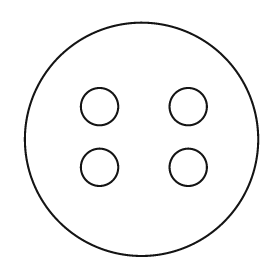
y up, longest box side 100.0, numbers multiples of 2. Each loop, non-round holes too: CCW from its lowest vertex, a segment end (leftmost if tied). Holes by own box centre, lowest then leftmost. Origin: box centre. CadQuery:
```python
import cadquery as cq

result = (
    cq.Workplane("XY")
    .moveTo(0.0, 0.0)
    .circle(50.0)
    .moveTo(-18.0, -12.0)
    .circle(8.0)
    .moveTo(20.0, -12.0)
    .circle(8.0)
    .moveTo(-18.0, 14.0)
    .circle(8.0)
    .moveTo(20.0, 14.0)
    .circle(8.0)
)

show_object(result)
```